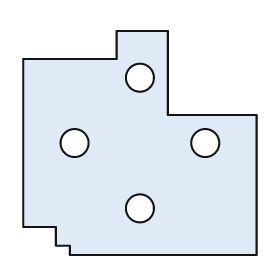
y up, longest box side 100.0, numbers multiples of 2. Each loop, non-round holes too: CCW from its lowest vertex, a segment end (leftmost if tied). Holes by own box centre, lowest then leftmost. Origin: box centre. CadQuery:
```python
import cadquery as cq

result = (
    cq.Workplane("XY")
    .moveTo(-30.0, -48.0)
    .lineTo(50.0, -48.0)
    .lineTo(50.0, 12.0)
    .lineTo(12.0, 12.0)
    .lineTo(12.0, 48.0)
    .lineTo(-10.0, 48.0)
    .lineTo(-10.0, 36.0)
    .lineTo(-50.0, 36.0)
    .lineTo(-50.0, -36.0)
    .lineTo(-36.0, -36.0)
    .lineTo(-36.0, -44.0)
    .lineTo(-30.0, -44.0)
    .close()
    .moveTo(0.0, -28.0)
    .circle(6.0)
    .moveTo(-28.0, 0.0)
    .circle(6.0)
    .moveTo(28.0, 0.0)
    .circle(6.0)
    .moveTo(0.0, 28.0)
    .circle(6.0)
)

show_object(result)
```